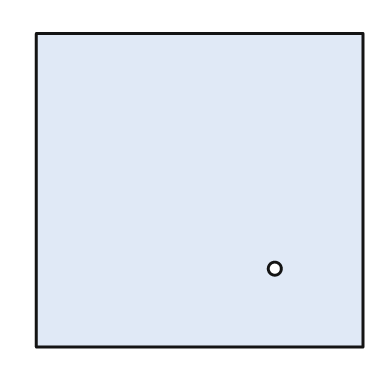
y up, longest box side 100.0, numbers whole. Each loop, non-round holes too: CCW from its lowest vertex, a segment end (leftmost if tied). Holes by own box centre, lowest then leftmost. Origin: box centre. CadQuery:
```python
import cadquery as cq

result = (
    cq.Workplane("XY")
    .moveTo(-50.0, -48.0)
    .lineTo(50.0, -48.0)
    .lineTo(50.0, 48.0)
    .lineTo(-50.0, 48.0)
    .close()
    .moveTo(23.0, -24.0)
    .circle(2.0)
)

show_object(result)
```